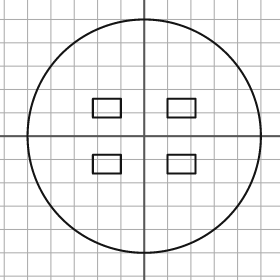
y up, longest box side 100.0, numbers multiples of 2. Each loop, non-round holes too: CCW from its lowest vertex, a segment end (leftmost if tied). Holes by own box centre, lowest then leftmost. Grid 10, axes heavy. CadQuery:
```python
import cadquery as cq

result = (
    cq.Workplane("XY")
    .moveTo(0.0, 0.0)
    .circle(50.0)
    .moveTo(-22.0, -16.0)
    .lineTo(-10.0, -16.0)
    .lineTo(-10.0, -8.0)
    .lineTo(-22.0, -8.0)
    .close()
    .moveTo(10.0, -16.0)
    .lineTo(22.0, -16.0)
    .lineTo(22.0, -8.0)
    .lineTo(10.0, -8.0)
    .close()
    .moveTo(-22.0, 8.0)
    .lineTo(-10.0, 8.0)
    .lineTo(-10.0, 16.0)
    .lineTo(-22.0, 16.0)
    .close()
    .moveTo(10.0, 8.0)
    .lineTo(22.0, 8.0)
    .lineTo(22.0, 16.0)
    .lineTo(10.0, 16.0)
    .close()
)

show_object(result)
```